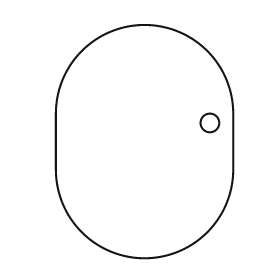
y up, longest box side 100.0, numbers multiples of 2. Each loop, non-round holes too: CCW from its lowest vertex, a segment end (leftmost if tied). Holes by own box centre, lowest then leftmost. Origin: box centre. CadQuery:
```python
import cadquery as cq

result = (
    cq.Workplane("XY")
    .moveTo(-38.0, -12.0)
    .threePointArc((0.0, -50.0), (38.0, -12.0))
    .lineTo(38.0, 12.0)
    .threePointArc((0.0, 50.0), (-38.0, 12.0))
    .close()
    .moveTo(28.0, 8.0)
    .circle(4.0)
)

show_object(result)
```